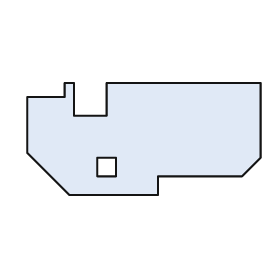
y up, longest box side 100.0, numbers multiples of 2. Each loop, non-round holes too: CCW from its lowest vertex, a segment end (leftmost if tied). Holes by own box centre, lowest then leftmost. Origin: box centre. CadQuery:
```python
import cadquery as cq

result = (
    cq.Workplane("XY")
    .moveTo(-32.0, -24.0)
    .lineTo(6.0, -24.0)
    .lineTo(6.0, -16.0)
    .lineTo(42.0, -16.0)
    .lineTo(50.0, -8.0)
    .lineTo(50.0, 24.0)
    .lineTo(-16.0, 24.0)
    .lineTo(-16.0, 10.0)
    .lineTo(-30.0, 10.0)
    .lineTo(-30.0, 24.0)
    .lineTo(-34.0, 24.0)
    .lineTo(-34.0, 18.0)
    .lineTo(-50.0, 18.0)
    .lineTo(-50.0, -6.0)
    .close()
    .moveTo(-20.0, -16.0)
    .lineTo(-12.0, -16.0)
    .lineTo(-12.0, -8.0)
    .lineTo(-20.0, -8.0)
    .close()
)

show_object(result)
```